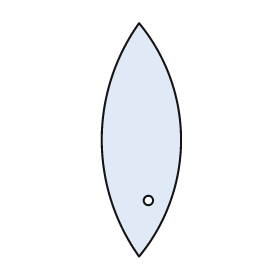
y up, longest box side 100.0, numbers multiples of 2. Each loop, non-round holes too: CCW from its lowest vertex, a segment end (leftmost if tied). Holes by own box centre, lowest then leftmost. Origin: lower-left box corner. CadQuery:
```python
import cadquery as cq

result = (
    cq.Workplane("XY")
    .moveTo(16.0, 0.0)
    .threePointArc((34.0, 50.0), (16.0, 100.0))
    .threePointArc((0.0, 50.0), (16.0, 0.0))
    .close()
    .moveTo(20.0, 24.0)
    .circle(2.0)
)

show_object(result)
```